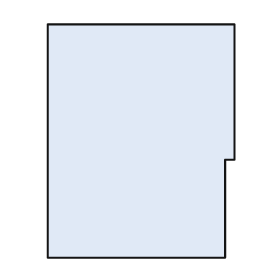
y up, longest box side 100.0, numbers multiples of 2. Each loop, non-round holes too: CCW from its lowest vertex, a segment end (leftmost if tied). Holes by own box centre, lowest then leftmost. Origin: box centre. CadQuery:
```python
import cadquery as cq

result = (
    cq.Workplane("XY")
    .moveTo(-40.0, -50.0)
    .lineTo(36.0, -50.0)
    .lineTo(36.0, -8.0)
    .lineTo(40.0, -8.0)
    .lineTo(40.0, 50.0)
    .lineTo(-40.0, 50.0)
    .close()
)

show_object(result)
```